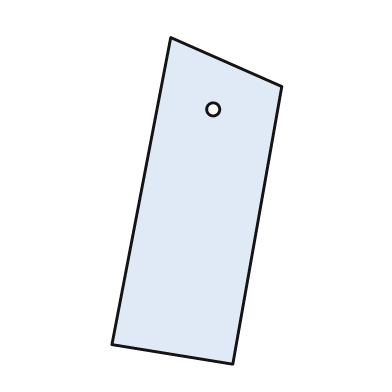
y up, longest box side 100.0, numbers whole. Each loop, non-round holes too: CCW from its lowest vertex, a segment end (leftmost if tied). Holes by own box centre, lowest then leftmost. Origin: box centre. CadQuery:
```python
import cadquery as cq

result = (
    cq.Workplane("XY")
    .moveTo(11.0, -50.0)
    .lineTo(26.0, 35.0)
    .lineTo(-8.0, 50.0)
    .lineTo(-26.0, -44.0)
    .close()
    .moveTo(5.0, 28.0)
    .circle(2.0)
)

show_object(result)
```